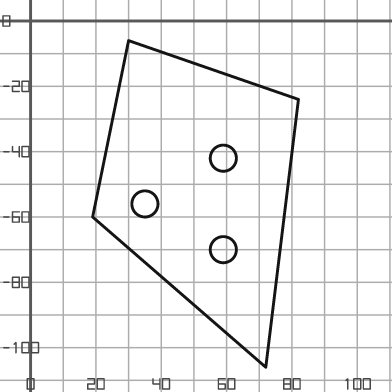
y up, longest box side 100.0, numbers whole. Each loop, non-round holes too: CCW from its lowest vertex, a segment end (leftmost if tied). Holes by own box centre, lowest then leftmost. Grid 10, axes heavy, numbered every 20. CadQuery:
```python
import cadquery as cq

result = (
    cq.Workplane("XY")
    .moveTo(72.0, -106.0)
    .lineTo(82.0, -24.0)
    .lineTo(30.0, -6.0)
    .lineTo(19.0, -60.0)
    .close()
    .moveTo(59.0, -70.0)
    .circle(4.0)
    .moveTo(35.0, -56.0)
    .circle(4.0)
    .moveTo(59.0, -42.0)
    .circle(4.0)
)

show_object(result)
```